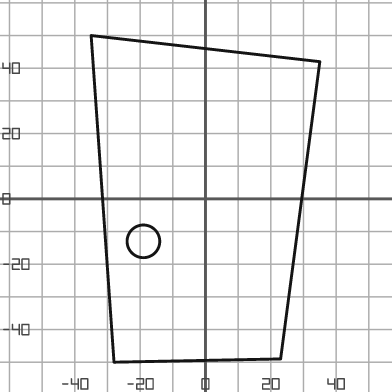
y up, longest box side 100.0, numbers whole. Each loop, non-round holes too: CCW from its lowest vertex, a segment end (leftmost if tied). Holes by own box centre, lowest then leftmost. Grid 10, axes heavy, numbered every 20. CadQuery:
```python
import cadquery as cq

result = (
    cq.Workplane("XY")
    .moveTo(-28.0, -50.0)
    .lineTo(23.0, -49.0)
    .lineTo(35.0, 42.0)
    .lineTo(-35.0, 50.0)
    .close()
    .moveTo(-19.0, -13.0)
    .circle(5.0)
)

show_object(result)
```